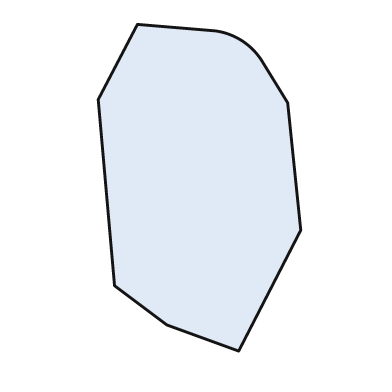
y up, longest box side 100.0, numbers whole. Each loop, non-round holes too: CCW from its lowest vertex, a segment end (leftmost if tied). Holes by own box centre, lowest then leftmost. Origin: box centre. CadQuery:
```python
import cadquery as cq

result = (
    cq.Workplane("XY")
    .moveTo(12.0, -50.0)
    .lineTo(31.0, -13.0)
    .lineTo(27.0, 26.0)
    .lineTo(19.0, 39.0)
    .threePointArc((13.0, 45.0), (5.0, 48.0))
    .lineTo(-19.0, 50.0)
    .lineTo(-31.0, 27.0)
    .lineTo(-26.0, -30.0)
    .lineTo(-10.0, -42.0)
    .close()
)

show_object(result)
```